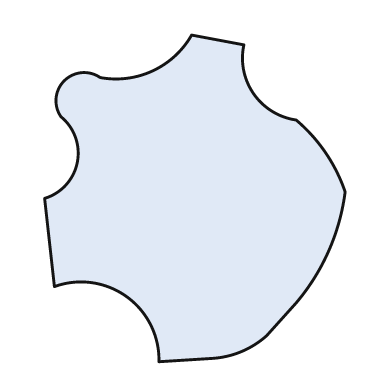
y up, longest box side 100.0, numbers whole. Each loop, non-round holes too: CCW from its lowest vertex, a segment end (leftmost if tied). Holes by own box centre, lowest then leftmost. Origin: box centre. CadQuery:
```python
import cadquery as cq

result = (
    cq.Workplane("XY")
    .moveTo(-11.0, -50.0)
    .lineTo(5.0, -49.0)
    .threePointArc((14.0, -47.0), (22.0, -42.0))
    .lineTo(31.0, -32.0)
    .threePointArc((41.0, -16.0), (46.0, 2.0))
    .threePointArc((40.0, 14.0), (31.0, 24.0))
    .threePointArc((18.0, 32.0), (15.0, 47.0))
    .lineTo(-1.0, 50.0)
    .threePointArc((-13.0, 39.0), (-29.0, 37.0))
    .threePointArc((-40.0, 36.0), (-41.0, 25.0))
    .threePointArc((-36.0, 11.0), (-46.0, 0.0))
    .lineTo(-43.0, -27.0)
    .threePointArc((-21.0, -30.0), (-11.0, -50.0))
    .close()
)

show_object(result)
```